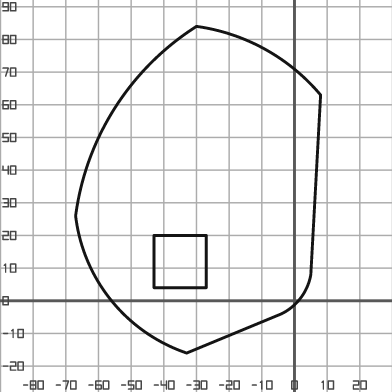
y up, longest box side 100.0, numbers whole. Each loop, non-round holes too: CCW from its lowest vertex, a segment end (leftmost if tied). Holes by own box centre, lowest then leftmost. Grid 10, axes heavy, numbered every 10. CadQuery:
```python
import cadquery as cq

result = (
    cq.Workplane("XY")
    .moveTo(-33.0, -16.0)
    .lineTo(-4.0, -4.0)
    .threePointArc((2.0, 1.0), (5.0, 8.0))
    .lineTo(8.0, 63.0)
    .threePointArc((-9.0, 77.0), (-30.0, 84.0))
    .threePointArc((-55.0, 59.0), (-67.0, 26.0))
    .threePointArc((-56.0, 0.0), (-33.0, -16.0))
    .close()
    .moveTo(-43.0, 4.0)
    .lineTo(-27.0, 4.0)
    .lineTo(-27.0, 20.0)
    .lineTo(-43.0, 20.0)
    .close()
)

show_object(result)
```